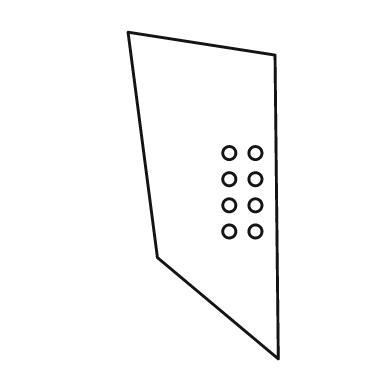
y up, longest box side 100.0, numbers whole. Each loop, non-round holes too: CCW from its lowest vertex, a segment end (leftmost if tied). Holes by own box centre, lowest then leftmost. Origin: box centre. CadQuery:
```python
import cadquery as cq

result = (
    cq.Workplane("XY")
    .moveTo(23.0, -50.0)
    .lineTo(22.0, 43.0)
    .lineTo(-23.0, 50.0)
    .lineTo(-14.0, -19.0)
    .close()
    .moveTo(8.0, -11.0)
    .circle(2.0)
    .moveTo(16.0, -11.0)
    .circle(2.0)
    .moveTo(8.0, -3.0)
    .circle(2.0)
    .moveTo(16.0, -3.0)
    .circle(2.0)
    .moveTo(8.0, 5.0)
    .circle(2.0)
    .moveTo(16.0, 5.0)
    .circle(2.0)
    .moveTo(8.0, 13.0)
    .circle(2.0)
    .moveTo(16.0, 13.0)
    .circle(2.0)
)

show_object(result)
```